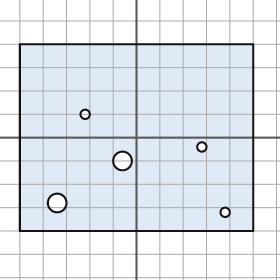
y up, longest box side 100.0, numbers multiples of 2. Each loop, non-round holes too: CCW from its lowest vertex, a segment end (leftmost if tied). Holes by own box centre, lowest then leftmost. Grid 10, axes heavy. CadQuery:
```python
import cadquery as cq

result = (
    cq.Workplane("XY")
    .moveTo(-50.0, -40.0)
    .lineTo(50.0, -40.0)
    .lineTo(50.0, 40.0)
    .lineTo(-50.0, 40.0)
    .close()
    .moveTo(38.0, -32.0)
    .circle(2.0)
    .moveTo(-34.0, -28.0)
    .circle(4.0)
    .moveTo(-6.0, -10.0)
    .circle(4.0)
    .moveTo(28.0, -4.0)
    .circle(2.0)
    .moveTo(-22.0, 10.0)
    .circle(2.0)
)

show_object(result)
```